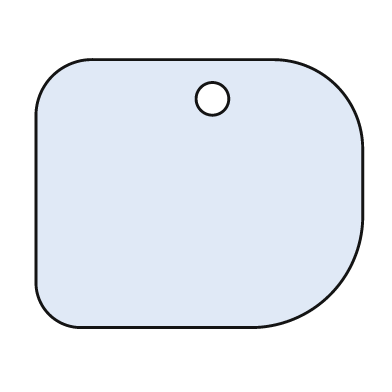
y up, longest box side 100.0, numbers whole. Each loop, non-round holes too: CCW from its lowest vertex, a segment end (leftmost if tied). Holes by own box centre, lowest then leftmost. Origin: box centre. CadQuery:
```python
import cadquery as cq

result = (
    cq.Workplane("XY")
    .moveTo(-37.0, -41.0)
    .lineTo(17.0, -41.0)
    .threePointArc((40.0, -31.0), (50.0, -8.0))
    .lineTo(50.0, 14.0)
    .threePointArc((42.0, 33.0), (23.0, 41.0))
    .lineTo(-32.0, 41.0)
    .threePointArc((-45.0, 36.0), (-50.0, 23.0))
    .lineTo(-50.0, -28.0)
    .threePointArc((-46.0, -37.0), (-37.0, -41.0))
    .close()
    .moveTo(4.0, 29.0)
    .circle(5.0)
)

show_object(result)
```